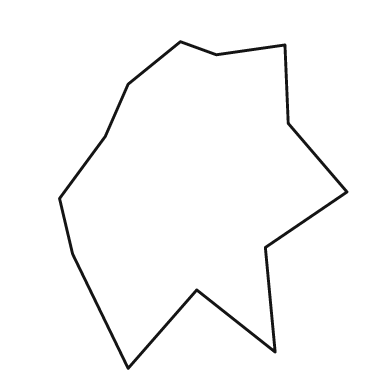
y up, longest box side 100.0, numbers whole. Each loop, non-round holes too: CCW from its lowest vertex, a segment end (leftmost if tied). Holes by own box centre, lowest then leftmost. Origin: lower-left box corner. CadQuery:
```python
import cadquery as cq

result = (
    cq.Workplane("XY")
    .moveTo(21.0, 0.0)
    .lineTo(42.0, 24.0)
    .lineTo(66.0, 5.0)
    .lineTo(63.0, 37.0)
    .lineTo(88.0, 54.0)
    .lineTo(70.0, 75.0)
    .lineTo(69.0, 99.0)
    .lineTo(48.0, 96.0)
    .lineTo(37.0, 100.0)
    .lineTo(21.0, 87.0)
    .lineTo(14.0, 71.0)
    .lineTo(0.0, 52.0)
    .lineTo(4.0, 35.0)
    .close()
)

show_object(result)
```